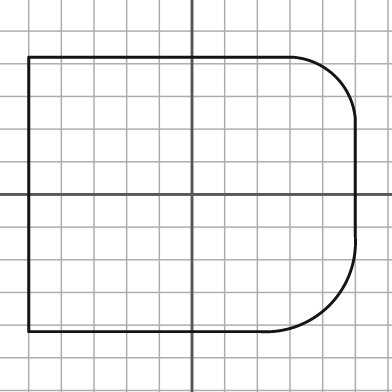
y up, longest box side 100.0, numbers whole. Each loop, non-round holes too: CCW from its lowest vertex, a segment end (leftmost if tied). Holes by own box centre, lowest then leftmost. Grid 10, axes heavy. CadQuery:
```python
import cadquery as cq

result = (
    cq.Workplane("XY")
    .moveTo(-50.0, -42.0)
    .lineTo(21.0, -42.0)
    .threePointArc((42.0, -34.0), (50.0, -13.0))
    .lineTo(50.0, 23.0)
    .threePointArc((44.0, 36.0), (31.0, 42.0))
    .lineTo(-50.0, 42.0)
    .close()
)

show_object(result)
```